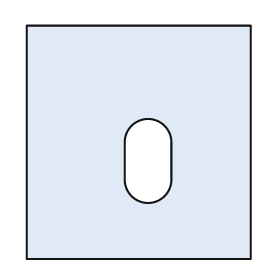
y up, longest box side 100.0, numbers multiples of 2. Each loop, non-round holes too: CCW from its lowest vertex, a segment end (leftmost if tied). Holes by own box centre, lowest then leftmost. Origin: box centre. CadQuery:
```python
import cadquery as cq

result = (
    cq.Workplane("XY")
    .moveTo(-48.0, -50.0)
    .lineTo(48.0, -50.0)
    .lineTo(48.0, 50.0)
    .lineTo(-48.0, 50.0)
    .close()
    .moveTo(-6.0, -16.0)
    .threePointArc((4.0, -26.0), (14.0, -16.0))
    .lineTo(14.0, 0.0)
    .threePointArc((4.0, 10.0), (-6.0, 0.0))
    .close()
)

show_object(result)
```